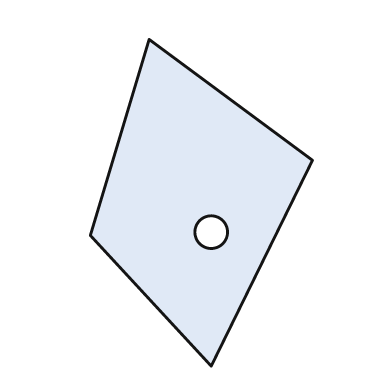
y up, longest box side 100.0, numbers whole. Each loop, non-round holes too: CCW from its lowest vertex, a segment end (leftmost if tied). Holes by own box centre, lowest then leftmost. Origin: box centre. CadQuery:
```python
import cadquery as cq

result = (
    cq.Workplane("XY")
    .moveTo(3.0, -50.0)
    .lineTo(34.0, 13.0)
    .lineTo(-16.0, 50.0)
    .lineTo(-34.0, -10.0)
    .close()
    .moveTo(3.0, -9.0)
    .circle(5.0)
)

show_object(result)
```